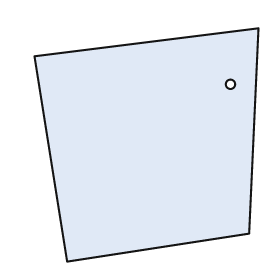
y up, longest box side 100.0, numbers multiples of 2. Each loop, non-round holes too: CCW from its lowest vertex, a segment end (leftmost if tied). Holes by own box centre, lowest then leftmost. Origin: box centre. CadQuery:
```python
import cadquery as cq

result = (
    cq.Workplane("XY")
    .moveTo(-34.0, -50.0)
    .lineTo(44.0, -38.0)
    .lineTo(48.0, 50.0)
    .lineTo(-48.0, 38.0)
    .close()
    .moveTo(36.0, 26.0)
    .circle(2.0)
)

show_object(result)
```